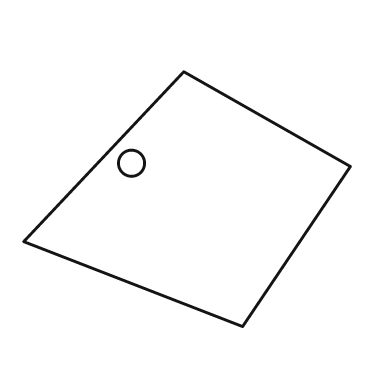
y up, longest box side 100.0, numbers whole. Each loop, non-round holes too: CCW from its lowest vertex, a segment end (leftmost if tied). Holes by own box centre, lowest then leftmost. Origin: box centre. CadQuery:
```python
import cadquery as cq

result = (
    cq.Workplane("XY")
    .moveTo(17.0, -39.0)
    .lineTo(50.0, 10.0)
    .lineTo(-1.0, 39.0)
    .lineTo(-50.0, -13.0)
    .close()
    .moveTo(-17.0, 11.0)
    .circle(4.0)
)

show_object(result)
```